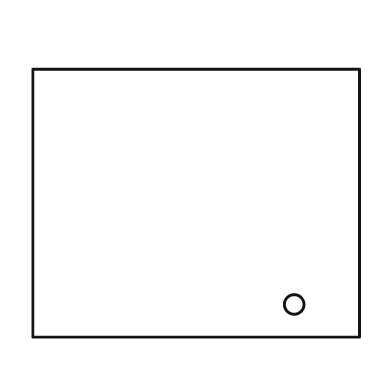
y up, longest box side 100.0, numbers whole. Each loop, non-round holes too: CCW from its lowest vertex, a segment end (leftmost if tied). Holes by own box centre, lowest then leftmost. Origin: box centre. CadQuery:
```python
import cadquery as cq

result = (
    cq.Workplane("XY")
    .moveTo(-50.0, -41.0)
    .lineTo(50.0, -41.0)
    .lineTo(50.0, 41.0)
    .lineTo(-50.0, 41.0)
    .close()
    .moveTo(30.0, -31.0)
    .circle(3.0)
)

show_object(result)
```